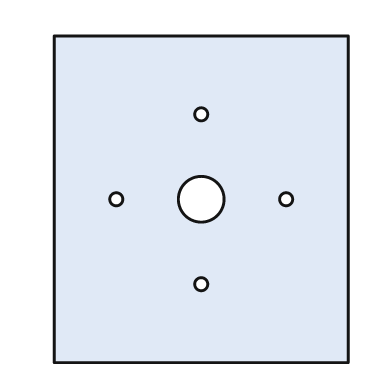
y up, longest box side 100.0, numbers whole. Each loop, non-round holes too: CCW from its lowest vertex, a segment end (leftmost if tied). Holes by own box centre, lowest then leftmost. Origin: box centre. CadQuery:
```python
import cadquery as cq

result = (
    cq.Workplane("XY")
    .moveTo(-45.0, -50.0)
    .lineTo(45.0, -50.0)
    .lineTo(45.0, 50.0)
    .lineTo(-45.0, 50.0)
    .close()
    .moveTo(0.0, -26.0)
    .circle(2.0)
    .moveTo(-26.0, 0.0)
    .circle(2.0)
    .moveTo(0.0, 0.0)
    .circle(7.0)
    .moveTo(26.0, 0.0)
    .circle(2.0)
    .moveTo(0.0, 26.0)
    .circle(2.0)
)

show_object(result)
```